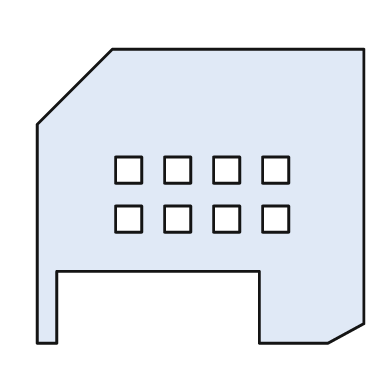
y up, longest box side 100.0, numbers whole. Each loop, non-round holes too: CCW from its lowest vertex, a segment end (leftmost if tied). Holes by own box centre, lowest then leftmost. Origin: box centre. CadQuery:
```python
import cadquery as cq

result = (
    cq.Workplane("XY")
    .moveTo(-50.0, -45.0)
    .lineTo(-44.0, -45.0)
    .lineTo(-44.0, -23.0)
    .lineTo(18.0, -23.0)
    .lineTo(18.0, -45.0)
    .lineTo(39.0, -45.0)
    .lineTo(50.0, -39.0)
    .lineTo(50.0, 45.0)
    .lineTo(-27.0, 45.0)
    .lineTo(-50.0, 22.0)
    .close()
    .moveTo(-26.0, -11.0)
    .lineTo(-18.0, -11.0)
    .lineTo(-18.0, -3.0)
    .lineTo(-26.0, -3.0)
    .close()
    .moveTo(-11.0, -11.0)
    .lineTo(-3.0, -11.0)
    .lineTo(-3.0, -3.0)
    .lineTo(-11.0, -3.0)
    .close()
    .moveTo(4.0, -11.0)
    .lineTo(12.0, -11.0)
    .lineTo(12.0, -3.0)
    .lineTo(4.0, -3.0)
    .close()
    .moveTo(19.0, -11.0)
    .lineTo(27.0, -11.0)
    .lineTo(27.0, -3.0)
    .lineTo(19.0, -3.0)
    .close()
    .moveTo(-26.0, 4.0)
    .lineTo(-18.0, 4.0)
    .lineTo(-18.0, 12.0)
    .lineTo(-26.0, 12.0)
    .close()
    .moveTo(-11.0, 4.0)
    .lineTo(-3.0, 4.0)
    .lineTo(-3.0, 12.0)
    .lineTo(-11.0, 12.0)
    .close()
    .moveTo(4.0, 4.0)
    .lineTo(12.0, 4.0)
    .lineTo(12.0, 12.0)
    .lineTo(4.0, 12.0)
    .close()
    .moveTo(19.0, 4.0)
    .lineTo(27.0, 4.0)
    .lineTo(27.0, 12.0)
    .lineTo(19.0, 12.0)
    .close()
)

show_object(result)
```